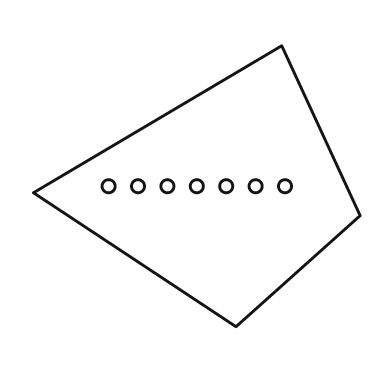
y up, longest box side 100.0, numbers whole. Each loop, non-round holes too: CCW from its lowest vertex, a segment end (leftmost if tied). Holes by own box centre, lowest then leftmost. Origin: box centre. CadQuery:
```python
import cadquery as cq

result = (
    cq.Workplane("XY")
    .moveTo(12.0, -43.0)
    .lineTo(50.0, -9.0)
    .lineTo(26.0, 43.0)
    .lineTo(-50.0, -2.0)
    .close()
    .moveTo(-27.0, 0.0)
    .circle(2.0)
    .moveTo(-18.0, 0.0)
    .circle(2.0)
    .moveTo(-9.0, 0.0)
    .circle(2.0)
    .moveTo(0.0, 0.0)
    .circle(2.0)
    .moveTo(9.0, 0.0)
    .circle(2.0)
    .moveTo(18.0, 0.0)
    .circle(2.0)
    .moveTo(27.0, 0.0)
    .circle(2.0)
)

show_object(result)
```